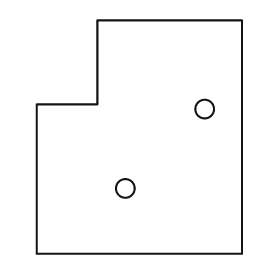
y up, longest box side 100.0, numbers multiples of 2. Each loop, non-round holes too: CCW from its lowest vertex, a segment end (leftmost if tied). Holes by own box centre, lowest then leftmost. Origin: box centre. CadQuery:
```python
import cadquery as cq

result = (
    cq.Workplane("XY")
    .moveTo(-44.0, -50.0)
    .lineTo(44.0, -50.0)
    .lineTo(44.0, 50.0)
    .lineTo(-18.0, 50.0)
    .lineTo(-18.0, 14.0)
    .lineTo(-44.0, 14.0)
    .close()
    .moveTo(-6.0, -22.0)
    .circle(4.0)
    .moveTo(28.0, 12.0)
    .circle(4.0)
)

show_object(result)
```